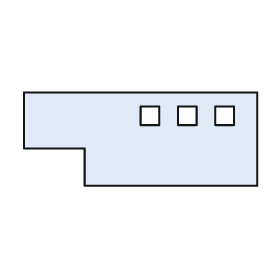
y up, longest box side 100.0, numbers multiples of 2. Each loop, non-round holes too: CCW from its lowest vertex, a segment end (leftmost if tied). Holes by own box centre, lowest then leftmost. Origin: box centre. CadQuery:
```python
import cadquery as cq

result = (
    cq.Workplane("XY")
    .moveTo(-24.0, -20.0)
    .lineTo(50.0, -20.0)
    .lineTo(50.0, 20.0)
    .lineTo(-50.0, 20.0)
    .lineTo(-50.0, -4.0)
    .lineTo(-24.0, -4.0)
    .close()
    .moveTo(0.0, 6.0)
    .lineTo(8.0, 6.0)
    .lineTo(8.0, 14.0)
    .lineTo(0.0, 14.0)
    .close()
    .moveTo(16.0, 6.0)
    .lineTo(24.0, 6.0)
    .lineTo(24.0, 14.0)
    .lineTo(16.0, 14.0)
    .close()
    .moveTo(32.0, 6.0)
    .lineTo(40.0, 6.0)
    .lineTo(40.0, 14.0)
    .lineTo(32.0, 14.0)
    .close()
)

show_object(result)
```